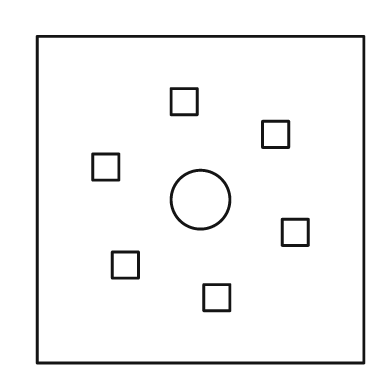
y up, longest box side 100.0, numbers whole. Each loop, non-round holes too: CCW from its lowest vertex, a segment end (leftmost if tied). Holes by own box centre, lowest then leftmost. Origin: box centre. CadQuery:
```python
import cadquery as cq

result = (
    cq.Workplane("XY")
    .moveTo(-50.0, -50.0)
    .lineTo(50.0, -50.0)
    .lineTo(50.0, 50.0)
    .lineTo(-50.0, 50.0)
    .close()
    .moveTo(1.0, -34.0)
    .lineTo(9.0, -34.0)
    .lineTo(9.0, -26.0)
    .lineTo(1.0, -26.0)
    .close()
    .moveTo(-27.0, -24.0)
    .lineTo(-19.0, -24.0)
    .lineTo(-19.0, -16.0)
    .lineTo(-27.0, -16.0)
    .close()
    .moveTo(25.0, -14.0)
    .lineTo(33.0, -14.0)
    .lineTo(33.0, -6.0)
    .lineTo(25.0, -6.0)
    .close()
    .moveTo(0.0, 0.0)
    .circle(9.0)
    .moveTo(-33.0, 6.0)
    .lineTo(-25.0, 6.0)
    .lineTo(-25.0, 14.0)
    .lineTo(-33.0, 14.0)
    .close()
    .moveTo(19.0, 16.0)
    .lineTo(27.0, 16.0)
    .lineTo(27.0, 24.0)
    .lineTo(19.0, 24.0)
    .close()
    .moveTo(-9.0, 26.0)
    .lineTo(-1.0, 26.0)
    .lineTo(-1.0, 34.0)
    .lineTo(-9.0, 34.0)
    .close()
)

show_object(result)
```